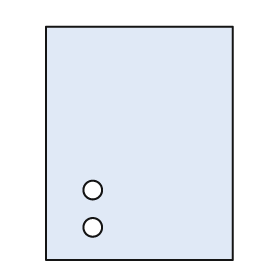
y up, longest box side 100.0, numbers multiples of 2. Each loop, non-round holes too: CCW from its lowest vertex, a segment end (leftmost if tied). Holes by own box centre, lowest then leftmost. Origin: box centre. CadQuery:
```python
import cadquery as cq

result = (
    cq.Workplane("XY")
    .moveTo(-40.0, -50.0)
    .lineTo(40.0, -50.0)
    .lineTo(40.0, 50.0)
    .lineTo(-40.0, 50.0)
    .close()
    .moveTo(-20.0, -36.0)
    .circle(4.0)
    .moveTo(-20.0, -20.0)
    .circle(4.0)
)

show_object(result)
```